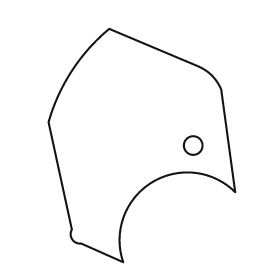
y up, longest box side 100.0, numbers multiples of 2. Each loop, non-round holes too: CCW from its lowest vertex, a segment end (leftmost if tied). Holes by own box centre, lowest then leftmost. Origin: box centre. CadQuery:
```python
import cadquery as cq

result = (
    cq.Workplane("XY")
    .moveTo(-8.0, -50.0)
    .threePointArc((4.0, -16.0), (40.0, -20.0))
    .lineTo(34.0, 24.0)
    .threePointArc((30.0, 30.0), (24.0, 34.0))
    .lineTo(-14.0, 50.0)
    .threePointArc((-30.0, 32.0), (-40.0, 10.0))
    .lineTo(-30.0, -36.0)
    .threePointArc((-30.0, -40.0), (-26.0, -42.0))
    .close()
    .moveTo(22.0, 0.0)
    .circle(4.0)
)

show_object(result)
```